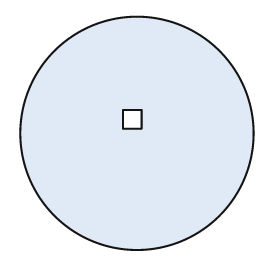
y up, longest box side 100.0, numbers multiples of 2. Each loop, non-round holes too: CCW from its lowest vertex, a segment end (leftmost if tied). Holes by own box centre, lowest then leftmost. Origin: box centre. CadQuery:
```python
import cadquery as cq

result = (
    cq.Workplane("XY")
    .moveTo(0.0, 0.0)
    .circle(50.0)
    .moveTo(-6.0, 2.0)
    .lineTo(2.0, 2.0)
    .lineTo(2.0, 10.0)
    .lineTo(-6.0, 10.0)
    .close()
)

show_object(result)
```